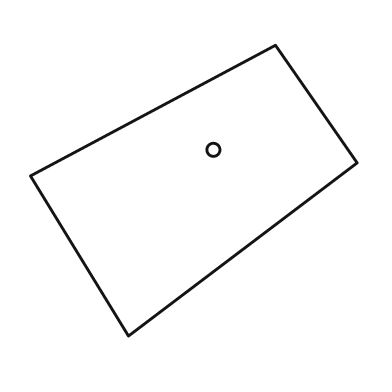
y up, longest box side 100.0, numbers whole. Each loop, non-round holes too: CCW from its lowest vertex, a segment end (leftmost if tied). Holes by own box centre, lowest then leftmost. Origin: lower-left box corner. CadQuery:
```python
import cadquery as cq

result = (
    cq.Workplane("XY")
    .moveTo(30.0, 0.0)
    .lineTo(100.0, 53.0)
    .lineTo(75.0, 89.0)
    .lineTo(0.0, 49.0)
    .close()
    .moveTo(56.0, 57.0)
    .circle(2.0)
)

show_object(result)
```